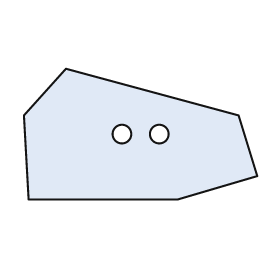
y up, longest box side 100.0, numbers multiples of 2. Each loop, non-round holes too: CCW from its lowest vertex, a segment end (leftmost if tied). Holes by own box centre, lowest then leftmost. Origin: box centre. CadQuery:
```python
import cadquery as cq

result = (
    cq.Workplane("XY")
    .moveTo(-48.0, -28.0)
    .lineTo(16.0, -28.0)
    .lineTo(50.0, -18.0)
    .lineTo(42.0, 8.0)
    .lineTo(-32.0, 28.0)
    .lineTo(-50.0, 8.0)
    .close()
    .moveTo(-8.0, 0.0)
    .circle(4.0)
    .moveTo(8.0, 0.0)
    .circle(4.0)
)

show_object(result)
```